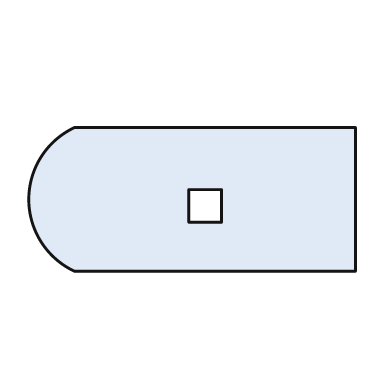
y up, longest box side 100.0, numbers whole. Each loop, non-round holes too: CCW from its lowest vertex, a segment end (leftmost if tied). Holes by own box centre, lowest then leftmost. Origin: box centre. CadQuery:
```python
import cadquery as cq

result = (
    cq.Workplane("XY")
    .moveTo(-36.0, -22.0)
    .lineTo(50.0, -22.0)
    .lineTo(50.0, 22.0)
    .lineTo(-36.0, 22.0)
    .threePointArc((-50.0, 0.0), (-36.0, -22.0))
    .close()
    .moveTo(-1.0, -7.0)
    .lineTo(9.0, -7.0)
    .lineTo(9.0, 3.0)
    .lineTo(-1.0, 3.0)
    .close()
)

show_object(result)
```